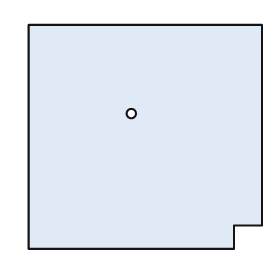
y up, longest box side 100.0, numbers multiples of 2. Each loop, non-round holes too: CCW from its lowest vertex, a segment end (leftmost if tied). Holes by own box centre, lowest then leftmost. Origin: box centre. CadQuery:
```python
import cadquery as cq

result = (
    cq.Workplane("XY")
    .moveTo(-50.0, -48.0)
    .lineTo(38.0, -48.0)
    .lineTo(38.0, -38.0)
    .lineTo(50.0, -38.0)
    .lineTo(50.0, 48.0)
    .lineTo(-50.0, 48.0)
    .close()
    .moveTo(-6.0, 10.0)
    .circle(2.0)
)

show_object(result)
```